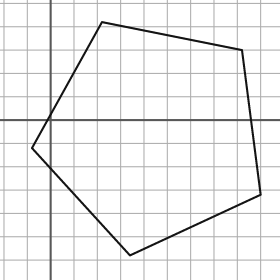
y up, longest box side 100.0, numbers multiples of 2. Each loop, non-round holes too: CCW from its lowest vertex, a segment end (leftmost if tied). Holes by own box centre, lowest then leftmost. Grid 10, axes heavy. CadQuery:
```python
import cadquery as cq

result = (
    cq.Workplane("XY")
    .moveTo(34.0, -58.0)
    .lineTo(90.0, -32.0)
    .lineTo(82.0, 30.0)
    .lineTo(22.0, 42.0)
    .lineTo(-8.0, -12.0)
    .close()
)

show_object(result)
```